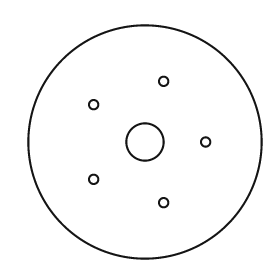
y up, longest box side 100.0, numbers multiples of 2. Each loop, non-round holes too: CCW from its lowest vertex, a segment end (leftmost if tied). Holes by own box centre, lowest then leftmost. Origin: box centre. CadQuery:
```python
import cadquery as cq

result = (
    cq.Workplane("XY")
    .moveTo(0.0, 0.0)
    .circle(50.0)
    .moveTo(8.0, -26.0)
    .circle(2.0)
    .moveTo(-22.0, -16.0)
    .circle(2.0)
    .moveTo(0.0, 0.0)
    .circle(8.0)
    .moveTo(26.0, 0.0)
    .circle(2.0)
    .moveTo(-22.0, 16.0)
    .circle(2.0)
    .moveTo(8.0, 26.0)
    .circle(2.0)
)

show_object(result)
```